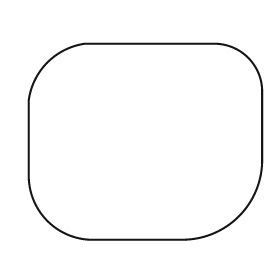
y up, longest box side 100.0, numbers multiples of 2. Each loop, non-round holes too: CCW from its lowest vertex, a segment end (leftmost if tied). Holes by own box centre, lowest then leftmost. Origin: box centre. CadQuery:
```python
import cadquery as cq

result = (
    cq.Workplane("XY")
    .moveTo(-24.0, -42.0)
    .lineTo(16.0, -42.0)
    .threePointArc((40.0, -32.0), (50.0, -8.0))
    .lineTo(50.0, 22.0)
    .threePointArc((44.0, 36.0), (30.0, 42.0))
    .lineTo(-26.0, 42.0)
    .threePointArc((-42.0, 34.0), (-50.0, 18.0))
    .lineTo(-50.0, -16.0)
    .threePointArc((-42.0, -34.0), (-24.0, -42.0))
    .close()
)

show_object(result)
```